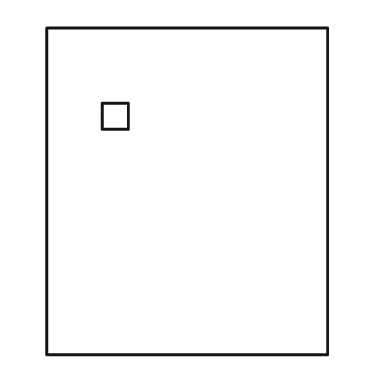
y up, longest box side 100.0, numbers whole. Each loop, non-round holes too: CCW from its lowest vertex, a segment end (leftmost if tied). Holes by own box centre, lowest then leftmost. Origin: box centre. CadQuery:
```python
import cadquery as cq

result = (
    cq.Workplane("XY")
    .moveTo(-43.0, -50.0)
    .lineTo(43.0, -50.0)
    .lineTo(43.0, 50.0)
    .lineTo(-43.0, 50.0)
    .close()
    .moveTo(-26.0, 19.0)
    .lineTo(-18.0, 19.0)
    .lineTo(-18.0, 27.0)
    .lineTo(-26.0, 27.0)
    .close()
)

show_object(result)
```